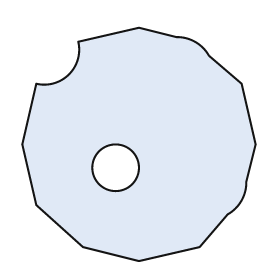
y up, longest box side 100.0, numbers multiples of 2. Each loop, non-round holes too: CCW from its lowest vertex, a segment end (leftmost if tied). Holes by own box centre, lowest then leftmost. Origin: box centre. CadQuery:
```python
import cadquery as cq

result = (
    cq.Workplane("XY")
    .moveTo(0.0, -50.0)
    .lineTo(26.0, -44.0)
    .lineTo(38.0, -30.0)
    .threePointArc((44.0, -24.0), (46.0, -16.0))
    .lineTo(50.0, 0.0)
    .lineTo(44.0, 26.0)
    .lineTo(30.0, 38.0)
    .threePointArc((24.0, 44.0), (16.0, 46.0))
    .lineTo(0.0, 50.0)
    .lineTo(-26.0, 44.0)
    .threePointArc((-30.0, 30.0), (-44.0, 26.0))
    .lineTo(-50.0, 0.0)
    .lineTo(-44.0, -26.0)
    .lineTo(-24.0, -44.0)
    .close()
    .moveTo(-10.0, -10.0)
    .circle(10.0)
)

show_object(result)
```